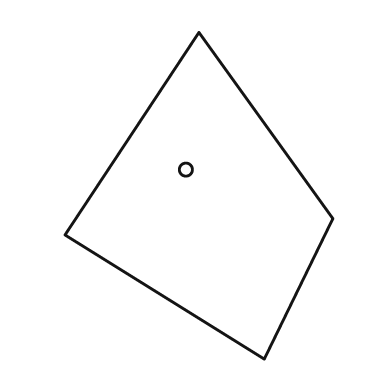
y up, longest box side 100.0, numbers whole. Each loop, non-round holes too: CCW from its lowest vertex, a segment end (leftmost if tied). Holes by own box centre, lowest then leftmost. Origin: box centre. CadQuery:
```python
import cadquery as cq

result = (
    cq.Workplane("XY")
    .moveTo(20.0, -50.0)
    .lineTo(41.0, -7.0)
    .lineTo(0.0, 50.0)
    .lineTo(-41.0, -12.0)
    .close()
    .moveTo(-4.0, 8.0)
    .circle(2.0)
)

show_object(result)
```